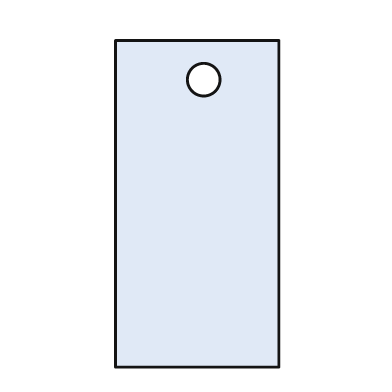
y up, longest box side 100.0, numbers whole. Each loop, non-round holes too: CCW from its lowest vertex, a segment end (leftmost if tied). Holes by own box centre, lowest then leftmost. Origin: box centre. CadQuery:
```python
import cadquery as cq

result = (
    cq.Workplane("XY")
    .moveTo(-25.0, -50.0)
    .lineTo(25.0, -50.0)
    .lineTo(25.0, 50.0)
    .lineTo(-25.0, 50.0)
    .close()
    .moveTo(2.0, 38.0)
    .circle(5.0)
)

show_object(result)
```